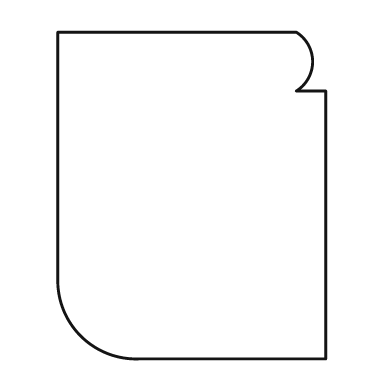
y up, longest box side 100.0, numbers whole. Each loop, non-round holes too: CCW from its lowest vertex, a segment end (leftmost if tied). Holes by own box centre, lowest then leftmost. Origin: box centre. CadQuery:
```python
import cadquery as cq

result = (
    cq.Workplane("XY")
    .moveTo(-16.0, -50.0)
    .lineTo(41.0, -50.0)
    .lineTo(41.0, 32.0)
    .lineTo(32.0, 32.0)
    .threePointArc((37.0, 41.0), (32.0, 50.0))
    .lineTo(-41.0, 50.0)
    .lineTo(-41.0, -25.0)
    .threePointArc((-34.0, -43.0), (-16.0, -50.0))
    .close()
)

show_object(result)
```